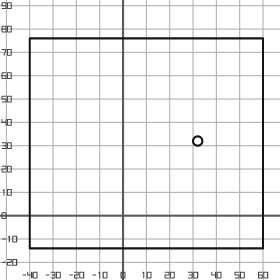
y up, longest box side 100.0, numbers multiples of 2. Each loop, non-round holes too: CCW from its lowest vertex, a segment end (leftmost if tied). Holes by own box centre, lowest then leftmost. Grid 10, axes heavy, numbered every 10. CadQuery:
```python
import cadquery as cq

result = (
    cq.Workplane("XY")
    .moveTo(-40.0, -14.0)
    .lineTo(60.0, -14.0)
    .lineTo(60.0, 76.0)
    .lineTo(-40.0, 76.0)
    .close()
    .moveTo(32.0, 32.0)
    .circle(2.0)
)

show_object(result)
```